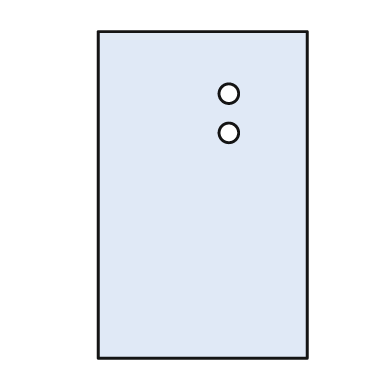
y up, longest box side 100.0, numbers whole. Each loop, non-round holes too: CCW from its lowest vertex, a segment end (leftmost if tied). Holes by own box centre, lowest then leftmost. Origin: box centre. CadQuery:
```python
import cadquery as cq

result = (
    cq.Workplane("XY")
    .moveTo(-32.0, -50.0)
    .lineTo(32.0, -50.0)
    .lineTo(32.0, 50.0)
    .lineTo(-32.0, 50.0)
    .close()
    .moveTo(8.0, 19.0)
    .circle(3.0)
    .moveTo(8.0, 31.0)
    .circle(3.0)
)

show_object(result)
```